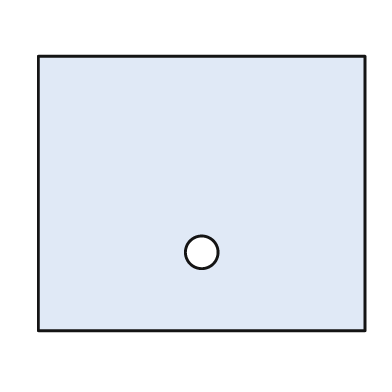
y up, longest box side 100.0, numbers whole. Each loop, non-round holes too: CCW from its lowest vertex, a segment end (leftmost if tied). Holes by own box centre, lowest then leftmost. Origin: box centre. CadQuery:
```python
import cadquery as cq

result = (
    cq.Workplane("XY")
    .moveTo(-50.0, -42.0)
    .lineTo(50.0, -42.0)
    .lineTo(50.0, 42.0)
    .lineTo(-50.0, 42.0)
    .close()
    .moveTo(0.0, -18.0)
    .circle(5.0)
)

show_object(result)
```